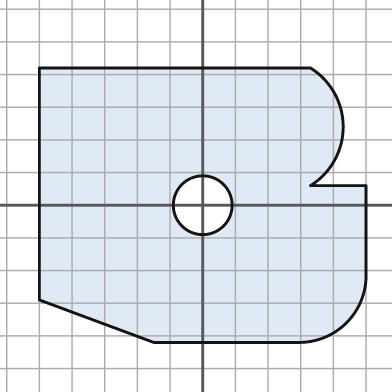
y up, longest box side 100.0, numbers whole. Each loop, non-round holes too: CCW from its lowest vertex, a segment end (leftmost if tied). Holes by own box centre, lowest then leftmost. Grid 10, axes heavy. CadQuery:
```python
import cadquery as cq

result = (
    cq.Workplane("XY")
    .moveTo(-15.0, -42.0)
    .lineTo(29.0, -42.0)
    .threePointArc((44.0, -36.0), (50.0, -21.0))
    .lineTo(50.0, 6.0)
    .lineTo(33.0, 6.0)
    .threePointArc((43.0, 24.0), (33.0, 42.0))
    .lineTo(-50.0, 42.0)
    .lineTo(-50.0, -29.0)
    .close()
    .moveTo(0.0, 0.0)
    .circle(9.0)
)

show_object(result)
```